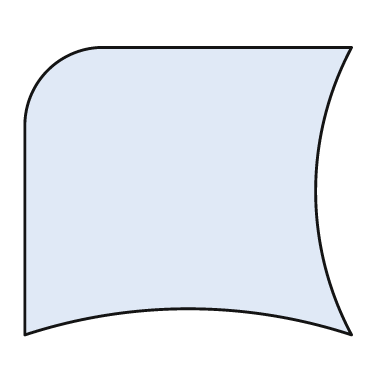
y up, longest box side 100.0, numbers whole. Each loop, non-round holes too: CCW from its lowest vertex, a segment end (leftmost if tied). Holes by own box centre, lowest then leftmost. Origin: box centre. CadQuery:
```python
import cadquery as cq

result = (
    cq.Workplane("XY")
    .moveTo(-50.0, -44.0)
    .threePointArc((0.0, -36.0), (50.0, -44.0))
    .threePointArc((39.0, 0.0), (50.0, 44.0))
    .lineTo(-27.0, 44.0)
    .threePointArc((-43.0, 37.0), (-50.0, 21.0))
    .close()
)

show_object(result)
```